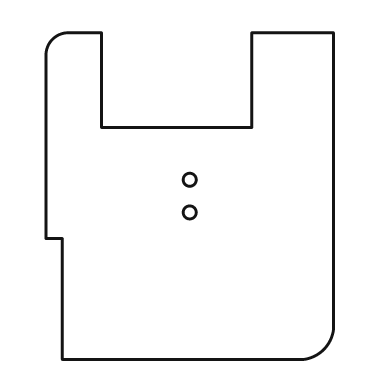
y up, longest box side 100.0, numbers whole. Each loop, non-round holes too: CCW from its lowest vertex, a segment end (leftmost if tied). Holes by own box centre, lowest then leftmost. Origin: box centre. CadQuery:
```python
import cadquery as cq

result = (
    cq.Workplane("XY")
    .moveTo(-39.0, -50.0)
    .lineTo(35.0, -50.0)
    .threePointArc((41.0, -47.0), (44.0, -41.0))
    .lineTo(44.0, 50.0)
    .lineTo(19.0, 50.0)
    .lineTo(19.0, 21.0)
    .lineTo(-27.0, 21.0)
    .lineTo(-27.0, 50.0)
    .lineTo(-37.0, 50.0)
    .threePointArc((-42.0, 48.0), (-44.0, 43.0))
    .lineTo(-44.0, -13.0)
    .lineTo(-39.0, -13.0)
    .close()
    .moveTo(0.0, -5.0)
    .circle(2.0)
    .moveTo(0.0, 5.0)
    .circle(2.0)
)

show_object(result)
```